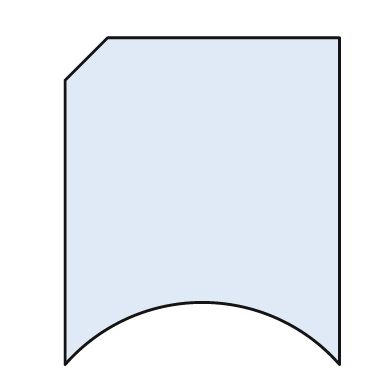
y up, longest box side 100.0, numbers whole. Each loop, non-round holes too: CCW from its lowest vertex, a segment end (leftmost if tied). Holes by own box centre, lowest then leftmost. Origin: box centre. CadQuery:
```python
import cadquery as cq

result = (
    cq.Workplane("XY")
    .moveTo(-42.0, -50.0)
    .threePointArc((0.0, -31.0), (42.0, -50.0))
    .lineTo(42.0, 50.0)
    .lineTo(-29.0, 50.0)
    .lineTo(-42.0, 37.0)
    .close()
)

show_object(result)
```